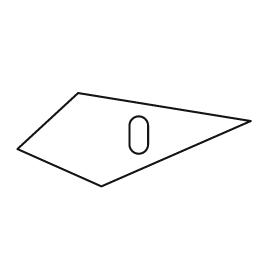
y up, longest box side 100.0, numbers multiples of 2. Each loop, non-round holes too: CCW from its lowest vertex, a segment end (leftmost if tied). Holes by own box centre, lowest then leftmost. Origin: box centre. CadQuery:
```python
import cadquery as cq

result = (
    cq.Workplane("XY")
    .moveTo(-14.0, -20.0)
    .lineTo(50.0, 8.0)
    .lineTo(-24.0, 20.0)
    .lineTo(-50.0, -4.0)
    .close()
    .moveTo(-2.0, -2.0)
    .threePointArc((2.0, -6.0), (6.0, -2.0))
    .lineTo(6.0, 6.0)
    .threePointArc((2.0, 10.0), (-2.0, 6.0))
    .close()
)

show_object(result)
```